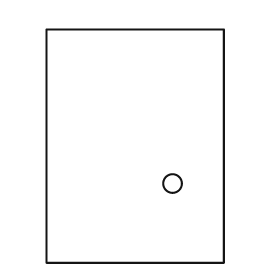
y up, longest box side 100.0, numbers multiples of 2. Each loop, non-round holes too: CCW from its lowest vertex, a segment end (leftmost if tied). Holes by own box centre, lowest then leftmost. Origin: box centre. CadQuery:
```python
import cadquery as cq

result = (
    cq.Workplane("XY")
    .moveTo(-38.0, -50.0)
    .lineTo(38.0, -50.0)
    .lineTo(38.0, 50.0)
    .lineTo(-38.0, 50.0)
    .close()
    .moveTo(16.0, -16.0)
    .circle(4.0)
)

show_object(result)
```